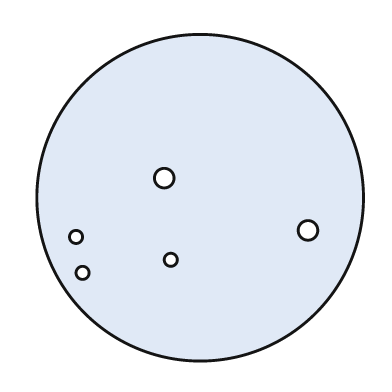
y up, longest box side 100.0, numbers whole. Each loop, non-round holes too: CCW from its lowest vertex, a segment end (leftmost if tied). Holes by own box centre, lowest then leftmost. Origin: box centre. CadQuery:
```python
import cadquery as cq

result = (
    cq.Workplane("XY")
    .moveTo(0.0, 0.0)
    .circle(50.0)
    .moveTo(-36.0, -23.0)
    .circle(2.0)
    .moveTo(-9.0, -19.0)
    .circle(2.0)
    .moveTo(-38.0, -12.0)
    .circle(2.0)
    .moveTo(33.0, -10.0)
    .circle(3.0)
    .moveTo(-11.0, 6.0)
    .circle(3.0)
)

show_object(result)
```